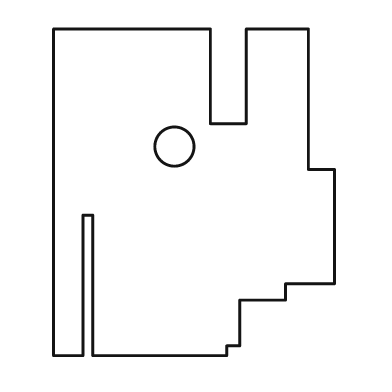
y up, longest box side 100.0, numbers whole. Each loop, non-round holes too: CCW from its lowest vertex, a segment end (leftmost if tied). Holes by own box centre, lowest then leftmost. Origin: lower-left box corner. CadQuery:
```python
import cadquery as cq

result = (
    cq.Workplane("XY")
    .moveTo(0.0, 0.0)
    .lineTo(9.0, 0.0)
    .lineTo(9.0, 43.0)
    .lineTo(12.0, 43.0)
    .lineTo(12.0, 0.0)
    .lineTo(53.0, 0.0)
    .lineTo(53.0, 3.0)
    .lineTo(57.0, 3.0)
    .lineTo(57.0, 17.0)
    .lineTo(71.0, 17.0)
    .lineTo(71.0, 22.0)
    .lineTo(86.0, 22.0)
    .lineTo(86.0, 57.0)
    .lineTo(78.0, 57.0)
    .lineTo(78.0, 100.0)
    .lineTo(59.0, 100.0)
    .lineTo(59.0, 71.0)
    .lineTo(48.0, 71.0)
    .lineTo(48.0, 100.0)
    .lineTo(0.0, 100.0)
    .close()
    .moveTo(37.0, 64.0)
    .circle(6.0)
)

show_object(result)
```